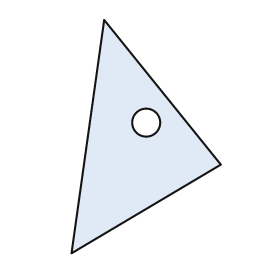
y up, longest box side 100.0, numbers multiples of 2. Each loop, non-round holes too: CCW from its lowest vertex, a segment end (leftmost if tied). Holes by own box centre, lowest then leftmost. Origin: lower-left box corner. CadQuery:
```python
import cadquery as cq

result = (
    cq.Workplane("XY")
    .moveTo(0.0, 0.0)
    .lineTo(64.0, 38.0)
    .lineTo(14.0, 100.0)
    .close()
    .moveTo(32.0, 56.0)
    .circle(6.0)
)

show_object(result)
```